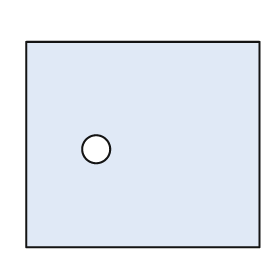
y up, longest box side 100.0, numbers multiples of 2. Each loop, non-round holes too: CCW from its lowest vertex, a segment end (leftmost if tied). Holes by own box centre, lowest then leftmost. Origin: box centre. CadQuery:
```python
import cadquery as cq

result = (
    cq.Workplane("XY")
    .moveTo(-50.0, -44.0)
    .lineTo(50.0, -44.0)
    .lineTo(50.0, 44.0)
    .lineTo(-50.0, 44.0)
    .close()
    .moveTo(-20.0, -2.0)
    .circle(6.0)
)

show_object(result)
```